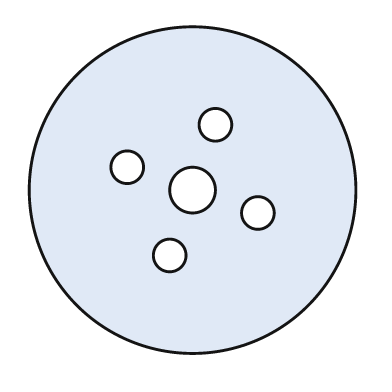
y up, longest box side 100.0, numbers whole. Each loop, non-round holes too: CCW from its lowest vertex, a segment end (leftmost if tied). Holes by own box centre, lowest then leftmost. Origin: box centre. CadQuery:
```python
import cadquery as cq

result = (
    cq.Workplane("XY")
    .moveTo(0.0, 0.0)
    .circle(50.0)
    .moveTo(-7.0, -20.0)
    .circle(5.0)
    .moveTo(20.0, -7.0)
    .circle(5.0)
    .moveTo(0.0, 0.0)
    .circle(7.0)
    .moveTo(-20.0, 7.0)
    .circle(5.0)
    .moveTo(7.0, 20.0)
    .circle(5.0)
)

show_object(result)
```